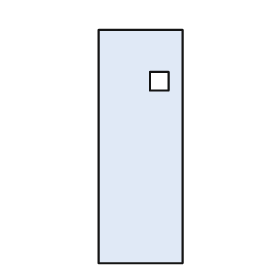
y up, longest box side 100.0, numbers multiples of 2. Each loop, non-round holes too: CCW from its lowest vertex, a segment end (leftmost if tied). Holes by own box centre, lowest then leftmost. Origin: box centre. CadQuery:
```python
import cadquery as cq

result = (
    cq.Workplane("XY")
    .moveTo(-18.0, -50.0)
    .lineTo(18.0, -50.0)
    .lineTo(18.0, 50.0)
    .lineTo(-18.0, 50.0)
    .close()
    .moveTo(4.0, 24.0)
    .lineTo(12.0, 24.0)
    .lineTo(12.0, 32.0)
    .lineTo(4.0, 32.0)
    .close()
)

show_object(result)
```